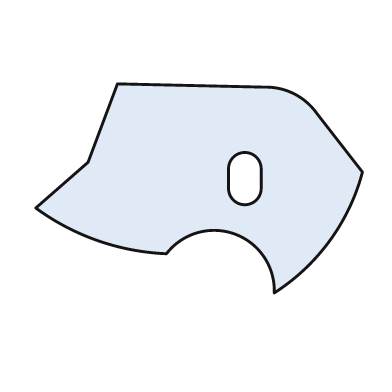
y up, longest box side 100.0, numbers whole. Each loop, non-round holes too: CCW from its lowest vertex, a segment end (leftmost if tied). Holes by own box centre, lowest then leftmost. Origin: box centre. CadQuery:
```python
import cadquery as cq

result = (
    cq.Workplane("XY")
    .moveTo(23.0, -32.0)
    .threePointArc((40.0, -16.0), (50.0, 5.0))
    .lineTo(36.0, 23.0)
    .threePointArc((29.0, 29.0), (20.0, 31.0))
    .lineTo(-25.0, 32.0)
    .lineTo(-34.0, 8.0)
    .lineTo(-50.0, -6.0)
    .threePointArc((-31.0, -16.0), (-10.0, -20.0))
    .threePointArc((11.0, -14.0), (23.0, -32.0))
    .close()
    .moveTo(9.0, 0.0)
    .threePointArc((14.0, -5.0), (19.0, 0.0))
    .lineTo(19.0, 6.0)
    .threePointArc((14.0, 11.0), (9.0, 6.0))
    .close()
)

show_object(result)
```